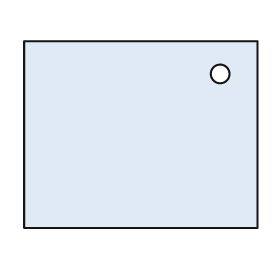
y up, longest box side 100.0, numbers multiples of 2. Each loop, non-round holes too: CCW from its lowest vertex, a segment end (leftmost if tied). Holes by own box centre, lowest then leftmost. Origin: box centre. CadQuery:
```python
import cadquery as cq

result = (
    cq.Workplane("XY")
    .moveTo(-50.0, -40.0)
    .lineTo(50.0, -40.0)
    .lineTo(50.0, 40.0)
    .lineTo(-50.0, 40.0)
    .close()
    .moveTo(34.0, 26.0)
    .circle(4.0)
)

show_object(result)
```